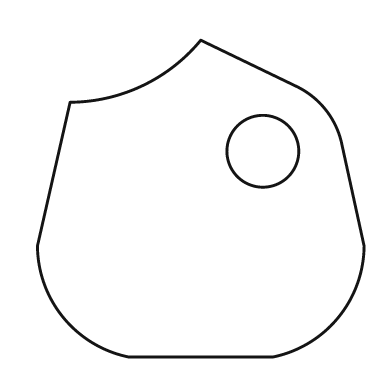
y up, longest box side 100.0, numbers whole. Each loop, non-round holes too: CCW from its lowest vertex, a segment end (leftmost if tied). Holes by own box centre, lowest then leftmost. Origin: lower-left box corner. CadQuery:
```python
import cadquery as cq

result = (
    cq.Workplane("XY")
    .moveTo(28.0, 0.0)
    .lineTo(72.0, 0.0)
    .threePointArc((92.0, 12.0), (100.0, 34.0))
    .lineTo(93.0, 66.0)
    .threePointArc((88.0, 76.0), (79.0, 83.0))
    .lineTo(50.0, 97.0)
    .threePointArc((32.0, 83.0), (10.0, 78.0))
    .lineTo(0.0, 34.0)
    .threePointArc((8.0, 12.0), (28.0, 0.0))
    .close()
    .moveTo(69.0, 63.0)
    .circle(11.0)
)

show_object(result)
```